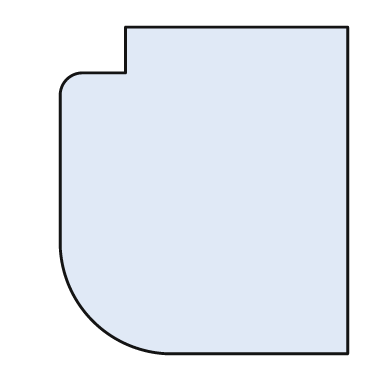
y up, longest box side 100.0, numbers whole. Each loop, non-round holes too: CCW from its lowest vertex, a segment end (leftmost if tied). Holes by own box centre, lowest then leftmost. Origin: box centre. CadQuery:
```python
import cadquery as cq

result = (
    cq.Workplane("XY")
    .moveTo(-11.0, -50.0)
    .lineTo(44.0, -50.0)
    .lineTo(44.0, 50.0)
    .lineTo(-24.0, 50.0)
    .lineTo(-24.0, 36.0)
    .lineTo(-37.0, 36.0)
    .threePointArc((-42.0, 34.0), (-44.0, 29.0))
    .lineTo(-44.0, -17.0)
    .threePointArc((-34.0, -40.0), (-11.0, -50.0))
    .close()
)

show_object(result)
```